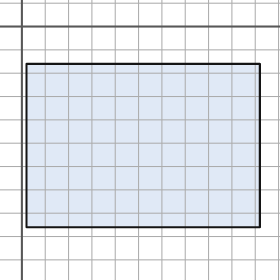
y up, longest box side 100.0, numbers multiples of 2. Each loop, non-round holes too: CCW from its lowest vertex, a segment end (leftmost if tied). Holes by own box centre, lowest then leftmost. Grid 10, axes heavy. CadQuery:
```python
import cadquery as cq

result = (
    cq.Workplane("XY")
    .moveTo(2.0, -86.0)
    .lineTo(102.0, -86.0)
    .lineTo(102.0, -16.0)
    .lineTo(2.0, -16.0)
    .close()
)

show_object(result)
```